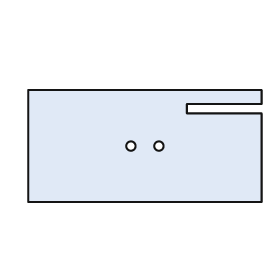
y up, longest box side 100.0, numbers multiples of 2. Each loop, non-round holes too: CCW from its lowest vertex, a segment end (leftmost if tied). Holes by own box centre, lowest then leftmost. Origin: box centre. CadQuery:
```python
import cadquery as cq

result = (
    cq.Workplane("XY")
    .moveTo(-50.0, -24.0)
    .lineTo(50.0, -24.0)
    .lineTo(50.0, 14.0)
    .lineTo(18.0, 14.0)
    .lineTo(18.0, 18.0)
    .lineTo(50.0, 18.0)
    .lineTo(50.0, 24.0)
    .lineTo(-50.0, 24.0)
    .close()
    .moveTo(-6.0, 0.0)
    .circle(2.0)
    .moveTo(6.0, 0.0)
    .circle(2.0)
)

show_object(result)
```